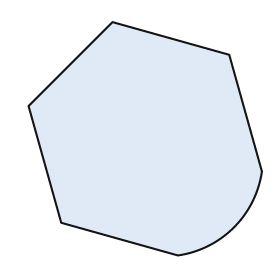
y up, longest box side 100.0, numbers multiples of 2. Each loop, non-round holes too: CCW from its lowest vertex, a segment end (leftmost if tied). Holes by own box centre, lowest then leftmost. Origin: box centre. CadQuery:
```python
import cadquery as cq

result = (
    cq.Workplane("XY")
    .moveTo(14.0, -50.0)
    .threePointArc((38.0, -38.0), (50.0, -14.0))
    .lineTo(36.0, 36.0)
    .lineTo(-14.0, 50.0)
    .lineTo(-50.0, 14.0)
    .lineTo(-36.0, -36.0)
    .close()
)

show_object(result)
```